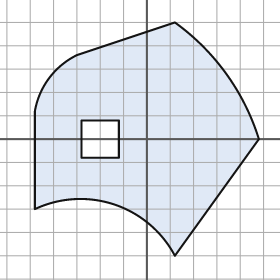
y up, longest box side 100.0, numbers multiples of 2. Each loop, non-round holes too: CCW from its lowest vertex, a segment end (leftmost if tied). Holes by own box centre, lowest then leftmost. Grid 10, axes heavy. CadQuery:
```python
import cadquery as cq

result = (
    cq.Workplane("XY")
    .moveTo(12.0, -50.0)
    .lineTo(48.0, 0.0)
    .threePointArc((34.0, 28.0), (12.0, 50.0))
    .lineTo(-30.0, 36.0)
    .threePointArc((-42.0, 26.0), (-48.0, 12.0))
    .lineTo(-48.0, -30.0)
    .threePointArc((-14.0, -28.0), (12.0, -50.0))
    .close()
    .moveTo(-28.0, -8.0)
    .lineTo(-12.0, -8.0)
    .lineTo(-12.0, 8.0)
    .lineTo(-28.0, 8.0)
    .close()
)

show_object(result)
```